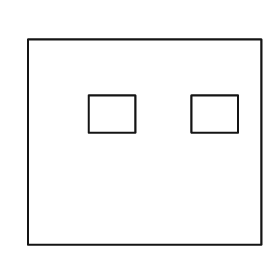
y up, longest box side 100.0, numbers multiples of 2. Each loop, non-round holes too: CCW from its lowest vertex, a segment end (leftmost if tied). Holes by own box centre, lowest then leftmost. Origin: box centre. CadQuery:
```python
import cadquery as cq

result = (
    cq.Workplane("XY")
    .moveTo(-50.0, -44.0)
    .lineTo(50.0, -44.0)
    .lineTo(50.0, 44.0)
    .lineTo(-50.0, 44.0)
    .close()
    .moveTo(-24.0, 4.0)
    .lineTo(-4.0, 4.0)
    .lineTo(-4.0, 20.0)
    .lineTo(-24.0, 20.0)
    .close()
    .moveTo(20.0, 4.0)
    .lineTo(40.0, 4.0)
    .lineTo(40.0, 20.0)
    .lineTo(20.0, 20.0)
    .close()
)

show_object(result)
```